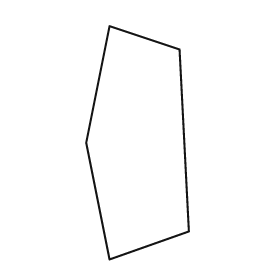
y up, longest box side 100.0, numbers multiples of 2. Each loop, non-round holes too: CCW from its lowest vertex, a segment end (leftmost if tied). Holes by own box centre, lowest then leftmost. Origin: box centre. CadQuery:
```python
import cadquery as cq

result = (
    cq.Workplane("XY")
    .moveTo(-12.0, -50.0)
    .lineTo(22.0, -38.0)
    .lineTo(18.0, 40.0)
    .lineTo(-12.0, 50.0)
    .lineTo(-22.0, 0.0)
    .close()
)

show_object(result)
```